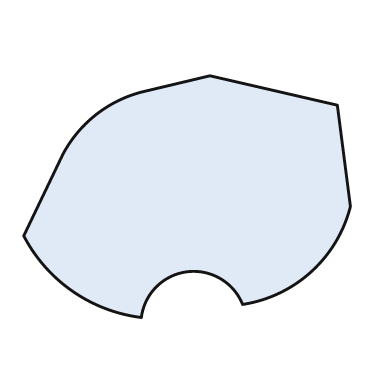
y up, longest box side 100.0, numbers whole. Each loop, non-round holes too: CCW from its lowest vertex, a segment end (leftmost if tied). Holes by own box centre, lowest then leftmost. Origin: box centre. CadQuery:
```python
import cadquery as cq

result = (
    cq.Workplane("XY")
    .moveTo(-14.0, -37.0)
    .threePointArc((0.0, -23.0), (17.0, -33.0))
    .threePointArc((38.0, -23.0), (50.0, -3.0))
    .lineTo(46.0, 28.0)
    .lineTo(7.0, 37.0)
    .lineTo(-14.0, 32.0)
    .threePointArc((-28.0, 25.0), (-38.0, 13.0))
    .lineTo(-50.0, -12.0)
    .threePointArc((-35.0, -29.0), (-14.0, -37.0))
    .close()
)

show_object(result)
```